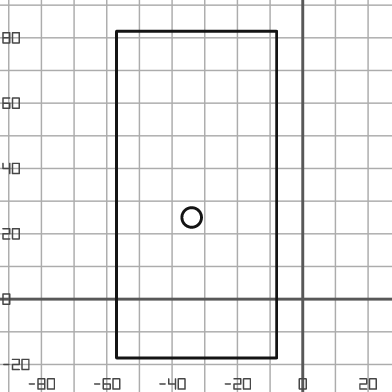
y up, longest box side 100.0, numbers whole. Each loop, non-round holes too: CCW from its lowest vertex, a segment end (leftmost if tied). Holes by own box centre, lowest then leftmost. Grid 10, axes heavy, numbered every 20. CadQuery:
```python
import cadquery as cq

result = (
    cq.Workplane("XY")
    .moveTo(-57.0, -18.0)
    .lineTo(-8.0, -18.0)
    .lineTo(-8.0, 82.0)
    .lineTo(-57.0, 82.0)
    .close()
    .moveTo(-34.0, 25.0)
    .circle(3.0)
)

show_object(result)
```